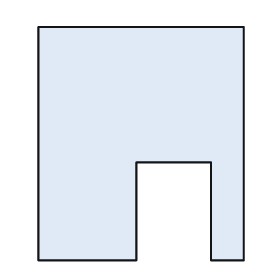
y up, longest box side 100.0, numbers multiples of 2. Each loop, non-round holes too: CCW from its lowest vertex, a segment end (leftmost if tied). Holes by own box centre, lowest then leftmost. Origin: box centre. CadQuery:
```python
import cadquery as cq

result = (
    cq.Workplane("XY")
    .moveTo(-44.0, -50.0)
    .lineTo(-2.0, -50.0)
    .lineTo(-2.0, -8.0)
    .lineTo(30.0, -8.0)
    .lineTo(30.0, -50.0)
    .lineTo(44.0, -50.0)
    .lineTo(44.0, 50.0)
    .lineTo(-44.0, 50.0)
    .close()
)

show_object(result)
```